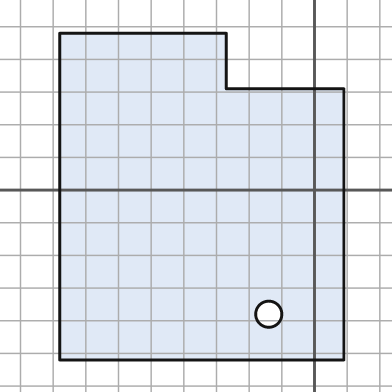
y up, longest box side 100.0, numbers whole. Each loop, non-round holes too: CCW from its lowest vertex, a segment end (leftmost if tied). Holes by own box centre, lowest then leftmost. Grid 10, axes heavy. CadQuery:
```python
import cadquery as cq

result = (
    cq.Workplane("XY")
    .moveTo(-78.0, -52.0)
    .lineTo(9.0, -52.0)
    .lineTo(9.0, 31.0)
    .lineTo(-27.0, 31.0)
    .lineTo(-27.0, 48.0)
    .lineTo(-78.0, 48.0)
    .close()
    .moveTo(-14.0, -38.0)
    .circle(4.0)
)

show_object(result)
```